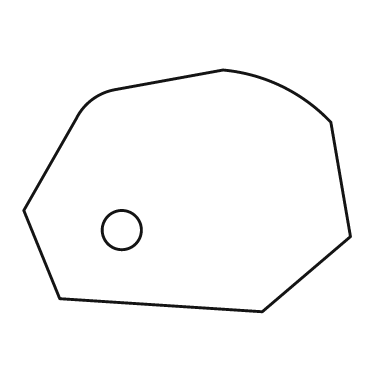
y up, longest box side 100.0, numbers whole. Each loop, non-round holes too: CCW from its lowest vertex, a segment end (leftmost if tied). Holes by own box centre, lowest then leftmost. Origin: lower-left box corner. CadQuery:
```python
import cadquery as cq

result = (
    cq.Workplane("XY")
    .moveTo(73.0, 0.0)
    .lineTo(100.0, 23.0)
    .lineTo(94.0, 58.0)
    .threePointArc((79.0, 69.0), (61.0, 74.0))
    .lineTo(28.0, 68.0)
    .threePointArc((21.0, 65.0), (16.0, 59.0))
    .lineTo(0.0, 31.0)
    .lineTo(11.0, 4.0)
    .close()
    .moveTo(30.0, 25.0)
    .circle(6.0)
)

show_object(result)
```